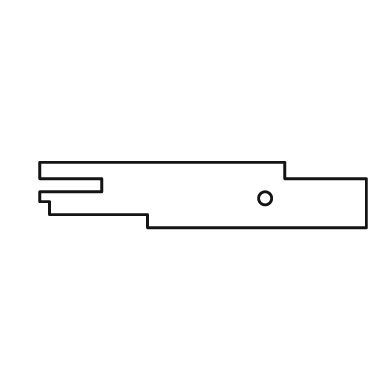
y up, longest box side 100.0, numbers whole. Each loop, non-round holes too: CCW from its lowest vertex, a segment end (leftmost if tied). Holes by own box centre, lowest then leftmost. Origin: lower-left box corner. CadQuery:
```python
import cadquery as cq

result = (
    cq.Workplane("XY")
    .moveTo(33.0, 0.0)
    .lineTo(100.0, 0.0)
    .lineTo(100.0, 15.0)
    .lineTo(75.0, 15.0)
    .lineTo(75.0, 20.0)
    .lineTo(0.0, 20.0)
    .lineTo(0.0, 15.0)
    .lineTo(19.0, 15.0)
    .lineTo(19.0, 11.0)
    .lineTo(0.0, 11.0)
    .lineTo(0.0, 8.0)
    .lineTo(3.0, 8.0)
    .lineTo(3.0, 4.0)
    .lineTo(33.0, 4.0)
    .close()
    .moveTo(69.0, 9.0)
    .circle(2.0)
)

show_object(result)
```